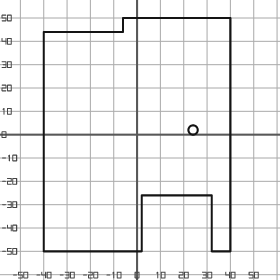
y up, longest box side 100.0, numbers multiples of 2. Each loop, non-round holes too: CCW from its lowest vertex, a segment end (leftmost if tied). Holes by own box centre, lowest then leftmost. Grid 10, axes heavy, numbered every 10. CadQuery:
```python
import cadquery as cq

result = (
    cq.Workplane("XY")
    .moveTo(-40.0, -50.0)
    .lineTo(2.0, -50.0)
    .lineTo(2.0, -26.0)
    .lineTo(32.0, -26.0)
    .lineTo(32.0, -50.0)
    .lineTo(40.0, -50.0)
    .lineTo(40.0, 50.0)
    .lineTo(-6.0, 50.0)
    .lineTo(-6.0, 44.0)
    .lineTo(-40.0, 44.0)
    .close()
    .moveTo(24.0, 2.0)
    .circle(2.0)
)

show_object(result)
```